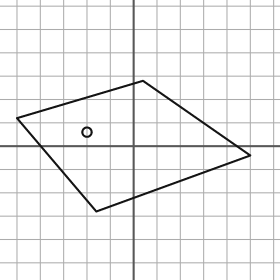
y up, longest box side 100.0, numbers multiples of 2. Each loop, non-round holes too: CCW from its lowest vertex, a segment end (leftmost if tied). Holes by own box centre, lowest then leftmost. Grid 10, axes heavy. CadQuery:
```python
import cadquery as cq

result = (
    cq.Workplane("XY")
    .moveTo(-16.0, -28.0)
    .lineTo(50.0, -4.0)
    .lineTo(4.0, 28.0)
    .lineTo(-50.0, 12.0)
    .close()
    .moveTo(-20.0, 6.0)
    .circle(2.0)
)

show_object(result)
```